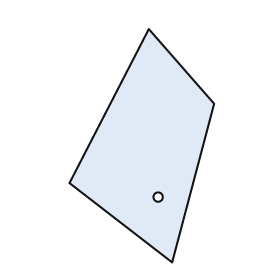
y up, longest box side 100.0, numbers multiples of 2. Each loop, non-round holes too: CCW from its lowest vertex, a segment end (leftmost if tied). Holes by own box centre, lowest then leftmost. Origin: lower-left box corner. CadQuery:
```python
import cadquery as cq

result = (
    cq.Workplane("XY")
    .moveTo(44.0, 0.0)
    .lineTo(62.0, 68.0)
    .lineTo(34.0, 100.0)
    .lineTo(0.0, 34.0)
    .close()
    .moveTo(38.0, 28.0)
    .circle(2.0)
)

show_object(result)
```